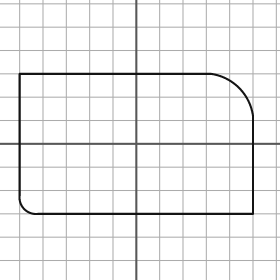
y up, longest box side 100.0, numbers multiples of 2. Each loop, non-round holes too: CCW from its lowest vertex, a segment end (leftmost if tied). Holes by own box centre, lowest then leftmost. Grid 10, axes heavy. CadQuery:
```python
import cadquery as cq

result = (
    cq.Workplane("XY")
    .moveTo(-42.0, -30.0)
    .lineTo(50.0, -30.0)
    .lineTo(50.0, 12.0)
    .threePointArc((44.0, 24.0), (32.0, 30.0))
    .lineTo(-50.0, 30.0)
    .lineTo(-50.0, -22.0)
    .threePointArc((-48.0, -28.0), (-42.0, -30.0))
    .close()
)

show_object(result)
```